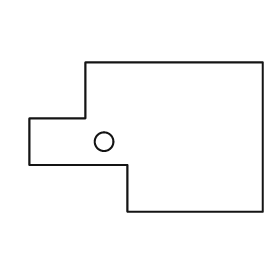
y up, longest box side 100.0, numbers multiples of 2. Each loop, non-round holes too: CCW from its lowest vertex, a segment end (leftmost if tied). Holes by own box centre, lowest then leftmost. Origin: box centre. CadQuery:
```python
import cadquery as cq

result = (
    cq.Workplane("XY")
    .moveTo(-8.0, -32.0)
    .lineTo(50.0, -32.0)
    .lineTo(50.0, 32.0)
    .lineTo(-26.0, 32.0)
    .lineTo(-26.0, 8.0)
    .lineTo(-50.0, 8.0)
    .lineTo(-50.0, -12.0)
    .lineTo(-8.0, -12.0)
    .close()
    .moveTo(-18.0, -2.0)
    .circle(4.0)
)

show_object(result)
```